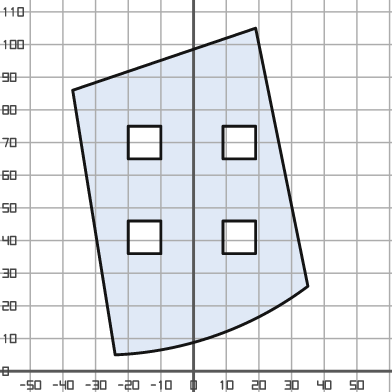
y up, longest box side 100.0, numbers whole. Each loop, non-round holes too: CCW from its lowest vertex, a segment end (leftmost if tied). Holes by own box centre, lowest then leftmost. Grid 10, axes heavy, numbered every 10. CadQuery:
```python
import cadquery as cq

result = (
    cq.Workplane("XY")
    .moveTo(-24.0, 5.0)
    .threePointArc((7.0, 11.0), (35.0, 26.0))
    .lineTo(19.0, 105.0)
    .lineTo(-37.0, 86.0)
    .close()
    .moveTo(-20.0, 36.0)
    .lineTo(-10.0, 36.0)
    .lineTo(-10.0, 46.0)
    .lineTo(-20.0, 46.0)
    .close()
    .moveTo(9.0, 36.0)
    .lineTo(19.0, 36.0)
    .lineTo(19.0, 46.0)
    .lineTo(9.0, 46.0)
    .close()
    .moveTo(-20.0, 65.0)
    .lineTo(-10.0, 65.0)
    .lineTo(-10.0, 75.0)
    .lineTo(-20.0, 75.0)
    .close()
    .moveTo(9.0, 65.0)
    .lineTo(19.0, 65.0)
    .lineTo(19.0, 75.0)
    .lineTo(9.0, 75.0)
    .close()
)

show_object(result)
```